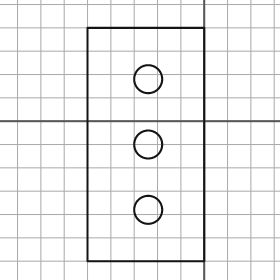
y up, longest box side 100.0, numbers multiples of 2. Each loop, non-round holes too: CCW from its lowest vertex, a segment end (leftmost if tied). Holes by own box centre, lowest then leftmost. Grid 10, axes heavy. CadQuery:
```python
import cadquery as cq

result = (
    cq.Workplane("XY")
    .moveTo(-50.0, -60.0)
    .lineTo(0.0, -60.0)
    .lineTo(0.0, 40.0)
    .lineTo(-50.0, 40.0)
    .close()
    .moveTo(-24.0, -38.0)
    .circle(6.0)
    .moveTo(-24.0, -10.0)
    .circle(6.0)
    .moveTo(-24.0, 18.0)
    .circle(6.0)
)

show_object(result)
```